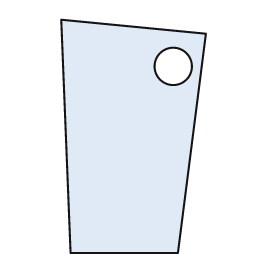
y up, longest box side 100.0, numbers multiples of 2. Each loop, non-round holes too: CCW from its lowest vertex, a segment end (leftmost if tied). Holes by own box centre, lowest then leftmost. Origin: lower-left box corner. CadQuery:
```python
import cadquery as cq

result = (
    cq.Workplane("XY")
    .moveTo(4.0, 0.0)
    .lineTo(50.0, 0.0)
    .lineTo(62.0, 94.0)
    .lineTo(0.0, 100.0)
    .close()
    .moveTo(48.0, 80.0)
    .circle(8.0)
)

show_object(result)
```